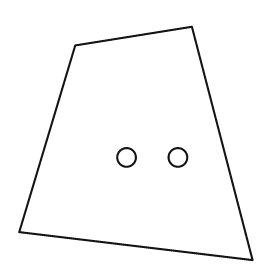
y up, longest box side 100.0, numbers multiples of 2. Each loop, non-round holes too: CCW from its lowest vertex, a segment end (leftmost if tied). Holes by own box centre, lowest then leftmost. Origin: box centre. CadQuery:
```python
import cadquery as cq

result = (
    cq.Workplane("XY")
    .moveTo(50.0, -50.0)
    .lineTo(24.0, 50.0)
    .lineTo(-26.0, 42.0)
    .lineTo(-50.0, -38.0)
    .close()
    .moveTo(-4.0, -6.0)
    .circle(4.0)
    .moveTo(18.0, -6.0)
    .circle(4.0)
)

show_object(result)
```